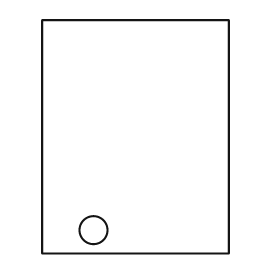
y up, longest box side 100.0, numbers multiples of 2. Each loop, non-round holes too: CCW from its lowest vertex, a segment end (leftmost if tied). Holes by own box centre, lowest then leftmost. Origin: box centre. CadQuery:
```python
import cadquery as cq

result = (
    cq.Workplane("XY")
    .moveTo(-40.0, -50.0)
    .lineTo(40.0, -50.0)
    .lineTo(40.0, 50.0)
    .lineTo(-40.0, 50.0)
    .close()
    .moveTo(-18.0, -40.0)
    .circle(6.0)
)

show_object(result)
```